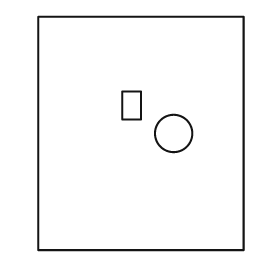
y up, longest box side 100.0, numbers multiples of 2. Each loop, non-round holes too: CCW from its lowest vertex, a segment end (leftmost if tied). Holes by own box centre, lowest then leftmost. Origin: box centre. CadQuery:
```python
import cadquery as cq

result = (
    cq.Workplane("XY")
    .moveTo(-44.0, -50.0)
    .lineTo(44.0, -50.0)
    .lineTo(44.0, 50.0)
    .lineTo(-44.0, 50.0)
    .close()
    .moveTo(14.0, 0.0)
    .circle(8.0)
    .moveTo(-8.0, 6.0)
    .lineTo(0.0, 6.0)
    .lineTo(0.0, 18.0)
    .lineTo(-8.0, 18.0)
    .close()
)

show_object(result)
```